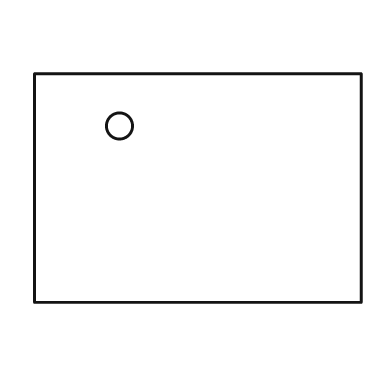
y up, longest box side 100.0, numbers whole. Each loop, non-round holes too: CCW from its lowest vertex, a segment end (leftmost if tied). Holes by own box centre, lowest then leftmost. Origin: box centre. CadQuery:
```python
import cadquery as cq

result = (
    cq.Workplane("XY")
    .moveTo(-50.0, -35.0)
    .lineTo(50.0, -35.0)
    .lineTo(50.0, 35.0)
    .lineTo(-50.0, 35.0)
    .close()
    .moveTo(-24.0, 19.0)
    .circle(4.0)
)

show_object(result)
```